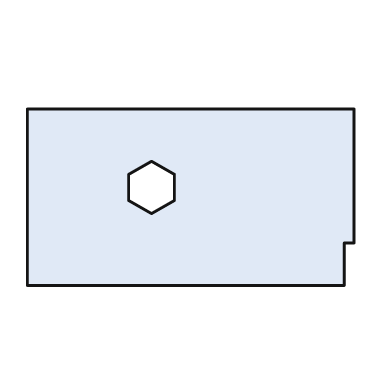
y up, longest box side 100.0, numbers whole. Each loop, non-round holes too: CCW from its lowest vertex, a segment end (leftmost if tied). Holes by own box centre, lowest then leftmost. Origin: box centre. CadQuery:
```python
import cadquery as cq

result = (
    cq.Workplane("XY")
    .moveTo(-50.0, -27.0)
    .lineTo(47.0, -27.0)
    .lineTo(47.0, -14.0)
    .lineTo(50.0, -14.0)
    .lineTo(50.0, 27.0)
    .lineTo(-50.0, 27.0)
    .close()
    .moveTo(-12.0, -5.0)
    .lineTo(-5.0, -1.0)
    .lineTo(-5.0, 7.0)
    .lineTo(-12.0, 11.0)
    .lineTo(-19.0, 7.0)
    .lineTo(-19.0, -1.0)
    .close()
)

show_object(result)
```